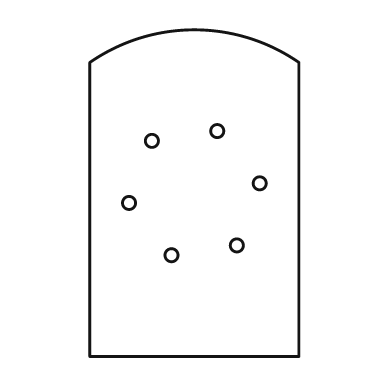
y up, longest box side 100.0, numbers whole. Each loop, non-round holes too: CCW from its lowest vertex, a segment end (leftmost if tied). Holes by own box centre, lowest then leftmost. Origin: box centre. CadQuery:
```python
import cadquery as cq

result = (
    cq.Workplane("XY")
    .moveTo(-32.0, -50.0)
    .lineTo(32.0, -50.0)
    .lineTo(32.0, 40.0)
    .threePointArc((0.0, 50.0), (-32.0, 40.0))
    .close()
    .moveTo(-7.0, -19.0)
    .circle(2.0)
    .moveTo(13.0, -16.0)
    .circle(2.0)
    .moveTo(-20.0, -3.0)
    .circle(2.0)
    .moveTo(20.0, 3.0)
    .circle(2.0)
    .moveTo(-13.0, 16.0)
    .circle(2.0)
    .moveTo(7.0, 19.0)
    .circle(2.0)
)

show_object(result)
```